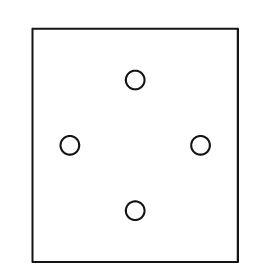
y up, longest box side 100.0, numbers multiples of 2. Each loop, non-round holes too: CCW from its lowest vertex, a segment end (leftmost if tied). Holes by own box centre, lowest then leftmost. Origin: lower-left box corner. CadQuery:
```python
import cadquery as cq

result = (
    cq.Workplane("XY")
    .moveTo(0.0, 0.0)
    .lineTo(88.0, 0.0)
    .lineTo(88.0, 100.0)
    .lineTo(0.0, 100.0)
    .close()
    .moveTo(44.0, 22.0)
    .circle(4.0)
    .moveTo(16.0, 50.0)
    .circle(4.0)
    .moveTo(72.0, 50.0)
    .circle(4.0)
    .moveTo(44.0, 78.0)
    .circle(4.0)
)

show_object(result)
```